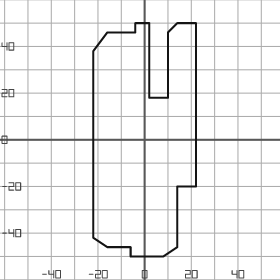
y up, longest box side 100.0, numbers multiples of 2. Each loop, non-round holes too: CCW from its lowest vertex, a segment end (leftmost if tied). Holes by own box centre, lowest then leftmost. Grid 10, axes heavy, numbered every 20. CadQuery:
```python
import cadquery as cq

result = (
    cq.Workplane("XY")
    .moveTo(-6.0, -50.0)
    .lineTo(8.0, -50.0)
    .lineTo(14.0, -46.0)
    .lineTo(14.0, -20.0)
    .lineTo(22.0, -20.0)
    .lineTo(22.0, 50.0)
    .lineTo(14.0, 50.0)
    .lineTo(10.0, 46.0)
    .lineTo(10.0, 18.0)
    .lineTo(2.0, 18.0)
    .lineTo(2.0, 50.0)
    .lineTo(-4.0, 50.0)
    .lineTo(-4.0, 46.0)
    .lineTo(-16.0, 46.0)
    .lineTo(-22.0, 38.0)
    .lineTo(-22.0, -42.0)
    .lineTo(-16.0, -46.0)
    .lineTo(-6.0, -46.0)
    .close()
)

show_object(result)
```